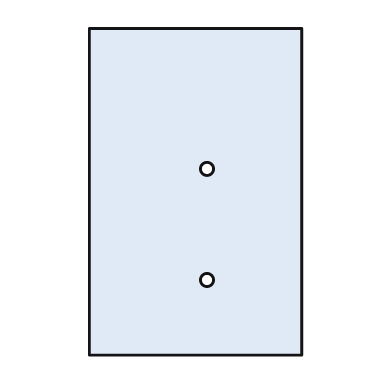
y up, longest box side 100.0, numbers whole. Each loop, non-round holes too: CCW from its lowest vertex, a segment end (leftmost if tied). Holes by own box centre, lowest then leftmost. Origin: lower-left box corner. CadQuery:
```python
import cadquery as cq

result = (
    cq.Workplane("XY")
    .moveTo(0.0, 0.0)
    .lineTo(65.0, 0.0)
    .lineTo(65.0, 100.0)
    .lineTo(0.0, 100.0)
    .close()
    .moveTo(36.0, 23.0)
    .circle(2.0)
    .moveTo(36.0, 57.0)
    .circle(2.0)
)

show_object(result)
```